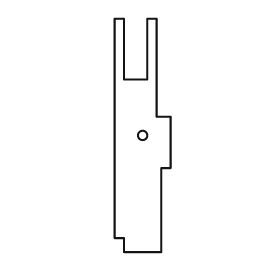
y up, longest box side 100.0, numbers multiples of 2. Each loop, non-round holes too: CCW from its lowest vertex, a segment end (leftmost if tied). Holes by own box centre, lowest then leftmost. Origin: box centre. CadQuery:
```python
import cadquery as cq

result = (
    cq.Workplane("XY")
    .moveTo(-8.0, -50.0)
    .lineTo(8.0, -50.0)
    .lineTo(8.0, -14.0)
    .lineTo(12.0, -14.0)
    .lineTo(12.0, 8.0)
    .lineTo(6.0, 8.0)
    .lineTo(6.0, 50.0)
    .lineTo(2.0, 50.0)
    .lineTo(2.0, 24.0)
    .lineTo(-8.0, 24.0)
    .lineTo(-8.0, 50.0)
    .lineTo(-12.0, 50.0)
    .lineTo(-12.0, -44.0)
    .lineTo(-8.0, -44.0)
    .close()
    .moveTo(0.0, 0.0)
    .circle(2.0)
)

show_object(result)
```